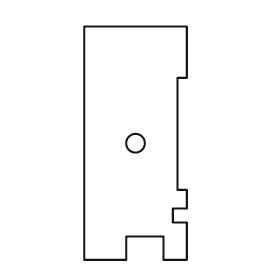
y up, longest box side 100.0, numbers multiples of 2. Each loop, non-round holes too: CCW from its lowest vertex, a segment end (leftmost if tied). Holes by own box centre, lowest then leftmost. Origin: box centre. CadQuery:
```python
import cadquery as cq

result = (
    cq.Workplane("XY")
    .moveTo(-22.0, -50.0)
    .lineTo(-4.0, -50.0)
    .lineTo(-4.0, -40.0)
    .lineTo(12.0, -40.0)
    .lineTo(12.0, -50.0)
    .lineTo(22.0, -50.0)
    .lineTo(22.0, -34.0)
    .lineTo(16.0, -34.0)
    .lineTo(16.0, -28.0)
    .lineTo(22.0, -28.0)
    .lineTo(22.0, -20.0)
    .lineTo(18.0, -20.0)
    .lineTo(18.0, 28.0)
    .lineTo(22.0, 28.0)
    .lineTo(22.0, 50.0)
    .lineTo(-22.0, 50.0)
    .close()
    .moveTo(0.0, 0.0)
    .circle(4.0)
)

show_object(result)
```